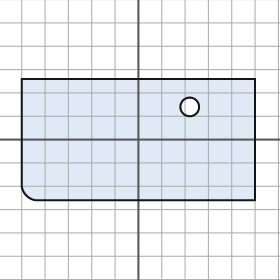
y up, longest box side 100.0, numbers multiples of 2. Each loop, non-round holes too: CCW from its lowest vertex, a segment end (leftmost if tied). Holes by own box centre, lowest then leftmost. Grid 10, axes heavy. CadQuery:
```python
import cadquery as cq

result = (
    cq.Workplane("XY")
    .moveTo(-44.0, -26.0)
    .lineTo(50.0, -26.0)
    .lineTo(50.0, 26.0)
    .lineTo(-50.0, 26.0)
    .lineTo(-50.0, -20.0)
    .threePointArc((-48.0, -24.0), (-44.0, -26.0))
    .close()
    .moveTo(22.0, 14.0)
    .circle(4.0)
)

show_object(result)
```